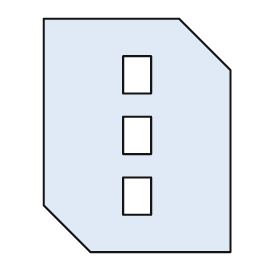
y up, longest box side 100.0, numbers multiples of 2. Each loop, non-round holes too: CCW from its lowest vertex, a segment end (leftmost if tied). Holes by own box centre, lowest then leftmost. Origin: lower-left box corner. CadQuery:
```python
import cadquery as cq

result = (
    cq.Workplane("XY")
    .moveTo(20.0, 0.0)
    .lineTo(80.0, 0.0)
    .lineTo(80.0, 78.0)
    .lineTo(58.0, 100.0)
    .lineTo(0.0, 100.0)
    .lineTo(0.0, 20.0)
    .close()
    .moveTo(34.0, 16.0)
    .lineTo(46.0, 16.0)
    .lineTo(46.0, 32.0)
    .lineTo(34.0, 32.0)
    .close()
    .moveTo(34.0, 42.0)
    .lineTo(46.0, 42.0)
    .lineTo(46.0, 58.0)
    .lineTo(34.0, 58.0)
    .close()
    .moveTo(34.0, 68.0)
    .lineTo(46.0, 68.0)
    .lineTo(46.0, 84.0)
    .lineTo(34.0, 84.0)
    .close()
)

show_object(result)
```